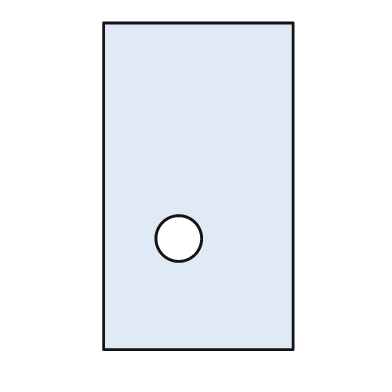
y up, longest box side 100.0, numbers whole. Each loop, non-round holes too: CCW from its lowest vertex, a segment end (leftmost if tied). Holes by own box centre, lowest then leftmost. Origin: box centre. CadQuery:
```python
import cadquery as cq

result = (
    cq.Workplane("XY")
    .moveTo(-29.0, -50.0)
    .lineTo(29.0, -50.0)
    .lineTo(29.0, 50.0)
    .lineTo(-29.0, 50.0)
    .close()
    .moveTo(-6.0, -16.0)
    .circle(7.0)
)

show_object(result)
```